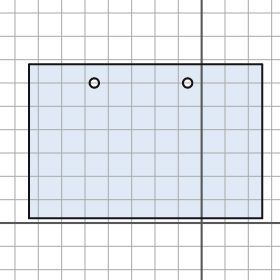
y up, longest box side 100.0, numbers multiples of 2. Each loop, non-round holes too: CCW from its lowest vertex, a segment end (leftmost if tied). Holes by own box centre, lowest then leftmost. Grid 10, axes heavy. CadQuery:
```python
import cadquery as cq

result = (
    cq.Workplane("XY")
    .moveTo(-74.0, 2.0)
    .lineTo(26.0, 2.0)
    .lineTo(26.0, 68.0)
    .lineTo(-74.0, 68.0)
    .close()
    .moveTo(-46.0, 60.0)
    .circle(2.0)
    .moveTo(-6.0, 60.0)
    .circle(2.0)
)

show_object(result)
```